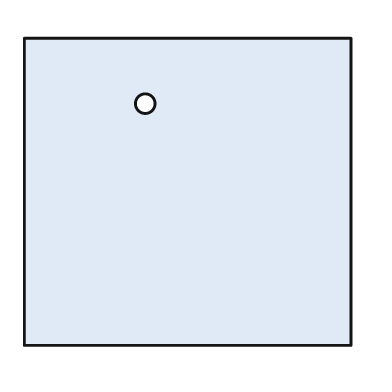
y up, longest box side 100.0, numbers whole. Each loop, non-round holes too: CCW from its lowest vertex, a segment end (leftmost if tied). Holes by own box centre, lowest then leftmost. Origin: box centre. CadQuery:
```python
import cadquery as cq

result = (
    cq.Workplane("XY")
    .moveTo(-50.0, -47.0)
    .lineTo(50.0, -47.0)
    .lineTo(50.0, 47.0)
    .lineTo(-50.0, 47.0)
    .close()
    .moveTo(-13.0, 27.0)
    .circle(3.0)
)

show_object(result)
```